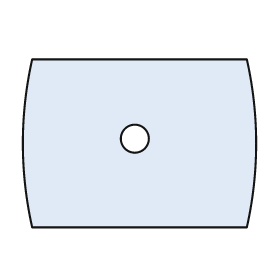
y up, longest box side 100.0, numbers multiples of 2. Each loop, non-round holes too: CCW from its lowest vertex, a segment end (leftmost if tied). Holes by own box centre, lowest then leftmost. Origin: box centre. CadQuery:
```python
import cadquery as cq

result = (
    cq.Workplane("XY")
    .moveTo(-46.0, -36.0)
    .lineTo(46.0, -36.0)
    .threePointArc((50.0, 0.0), (46.0, 36.0))
    .lineTo(-46.0, 36.0)
    .threePointArc((-50.0, 0.0), (-46.0, -36.0))
    .close()
    .moveTo(-2.0, 2.0)
    .circle(6.0)
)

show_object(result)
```